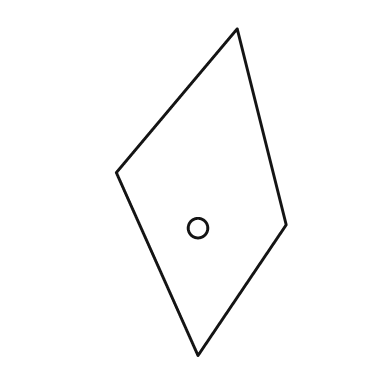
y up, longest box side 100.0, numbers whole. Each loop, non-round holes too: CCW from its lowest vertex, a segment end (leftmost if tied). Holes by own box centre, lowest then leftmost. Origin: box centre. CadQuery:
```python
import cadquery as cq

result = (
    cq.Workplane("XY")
    .moveTo(-1.0, -50.0)
    .lineTo(26.0, -10.0)
    .lineTo(11.0, 50.0)
    .lineTo(-26.0, 6.0)
    .close()
    .moveTo(-1.0, -11.0)
    .circle(3.0)
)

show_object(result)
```